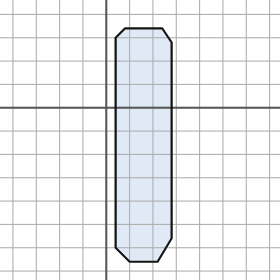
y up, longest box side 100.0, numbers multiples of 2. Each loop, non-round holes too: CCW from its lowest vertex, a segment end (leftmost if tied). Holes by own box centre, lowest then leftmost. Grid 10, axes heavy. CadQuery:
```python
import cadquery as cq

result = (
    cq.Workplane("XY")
    .moveTo(10.0, -66.0)
    .lineTo(22.0, -66.0)
    .lineTo(28.0, -56.0)
    .lineTo(28.0, 28.0)
    .lineTo(24.0, 34.0)
    .lineTo(8.0, 34.0)
    .lineTo(4.0, 30.0)
    .lineTo(4.0, -60.0)
    .close()
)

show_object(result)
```